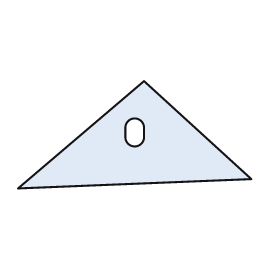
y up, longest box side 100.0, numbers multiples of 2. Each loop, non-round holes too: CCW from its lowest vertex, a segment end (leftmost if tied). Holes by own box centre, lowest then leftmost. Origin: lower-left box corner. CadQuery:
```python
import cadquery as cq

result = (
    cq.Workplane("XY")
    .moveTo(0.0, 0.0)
    .lineTo(100.0, 4.0)
    .lineTo(54.0, 46.0)
    .close()
    .moveTo(46.0, 22.0)
    .threePointArc((50.0, 18.0), (54.0, 22.0))
    .lineTo(54.0, 26.0)
    .threePointArc((50.0, 30.0), (46.0, 26.0))
    .close()
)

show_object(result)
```